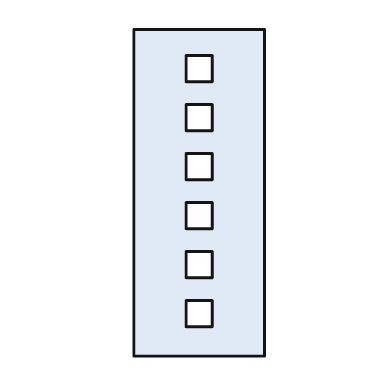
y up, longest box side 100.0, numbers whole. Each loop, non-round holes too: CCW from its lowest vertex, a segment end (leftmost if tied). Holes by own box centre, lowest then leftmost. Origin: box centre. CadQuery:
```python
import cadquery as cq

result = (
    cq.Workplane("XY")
    .moveTo(-20.0, -50.0)
    .lineTo(20.0, -50.0)
    .lineTo(20.0, 50.0)
    .lineTo(-20.0, 50.0)
    .close()
    .moveTo(-4.0, -41.0)
    .lineTo(4.0, -41.0)
    .lineTo(4.0, -33.0)
    .lineTo(-4.0, -33.0)
    .close()
    .moveTo(-4.0, -26.0)
    .lineTo(4.0, -26.0)
    .lineTo(4.0, -18.0)
    .lineTo(-4.0, -18.0)
    .close()
    .moveTo(-4.0, -11.0)
    .lineTo(4.0, -11.0)
    .lineTo(4.0, -3.0)
    .lineTo(-4.0, -3.0)
    .close()
    .moveTo(-4.0, 4.0)
    .lineTo(4.0, 4.0)
    .lineTo(4.0, 12.0)
    .lineTo(-4.0, 12.0)
    .close()
    .moveTo(-4.0, 19.0)
    .lineTo(4.0, 19.0)
    .lineTo(4.0, 27.0)
    .lineTo(-4.0, 27.0)
    .close()
    .moveTo(-4.0, 34.0)
    .lineTo(4.0, 34.0)
    .lineTo(4.0, 42.0)
    .lineTo(-4.0, 42.0)
    .close()
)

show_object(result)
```